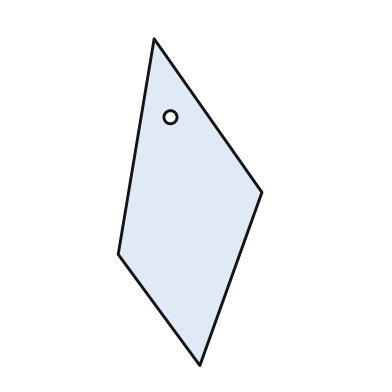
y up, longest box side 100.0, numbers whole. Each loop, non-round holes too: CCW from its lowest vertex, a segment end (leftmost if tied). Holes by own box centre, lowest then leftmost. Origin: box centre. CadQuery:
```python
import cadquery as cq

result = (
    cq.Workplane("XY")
    .moveTo(3.0, -50.0)
    .lineTo(22.0, 3.0)
    .lineTo(-11.0, 50.0)
    .lineTo(-22.0, -16.0)
    .close()
    .moveTo(-6.0, 26.0)
    .circle(2.0)
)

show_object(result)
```